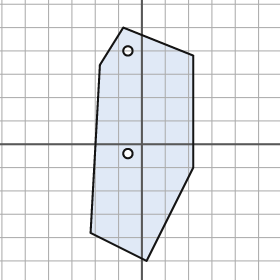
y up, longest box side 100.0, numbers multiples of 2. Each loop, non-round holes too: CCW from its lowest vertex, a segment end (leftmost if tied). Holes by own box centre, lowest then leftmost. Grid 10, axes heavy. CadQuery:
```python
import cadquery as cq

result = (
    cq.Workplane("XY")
    .moveTo(2.0, -50.0)
    .lineTo(22.0, -10.0)
    .lineTo(22.0, 38.0)
    .lineTo(-8.0, 50.0)
    .lineTo(-18.0, 34.0)
    .lineTo(-22.0, -38.0)
    .close()
    .moveTo(-6.0, -4.0)
    .circle(2.0)
    .moveTo(-6.0, 40.0)
    .circle(2.0)
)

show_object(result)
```